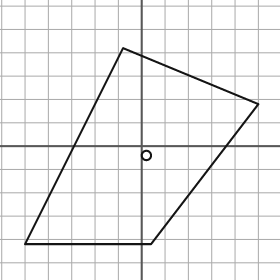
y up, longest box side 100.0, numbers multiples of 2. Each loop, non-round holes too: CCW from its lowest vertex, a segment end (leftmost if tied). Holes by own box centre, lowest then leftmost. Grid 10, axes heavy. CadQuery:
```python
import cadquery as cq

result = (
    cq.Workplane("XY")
    .moveTo(-50.0, -42.0)
    .lineTo(4.0, -42.0)
    .lineTo(50.0, 18.0)
    .lineTo(-8.0, 42.0)
    .close()
    .moveTo(2.0, -4.0)
    .circle(2.0)
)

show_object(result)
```